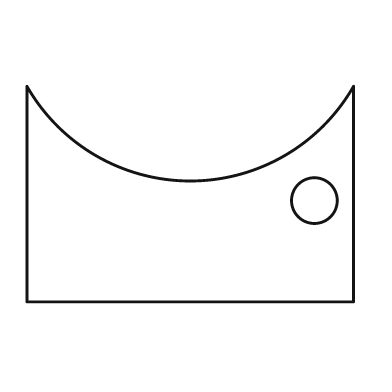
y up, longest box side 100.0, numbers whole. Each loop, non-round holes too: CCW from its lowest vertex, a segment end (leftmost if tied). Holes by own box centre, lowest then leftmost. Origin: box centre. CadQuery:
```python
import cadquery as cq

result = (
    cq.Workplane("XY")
    .moveTo(-50.0, -33.0)
    .lineTo(50.0, -33.0)
    .lineTo(50.0, 33.0)
    .threePointArc((0.0, 4.0), (-50.0, 33.0))
    .close()
    .moveTo(38.0, -2.0)
    .circle(7.0)
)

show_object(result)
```